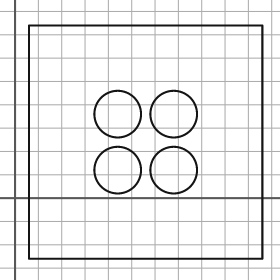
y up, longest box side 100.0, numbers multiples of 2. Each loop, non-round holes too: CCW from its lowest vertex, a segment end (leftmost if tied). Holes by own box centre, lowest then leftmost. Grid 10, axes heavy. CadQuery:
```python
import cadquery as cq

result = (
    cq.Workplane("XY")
    .moveTo(6.0, -26.0)
    .lineTo(106.0, -26.0)
    .lineTo(106.0, 74.0)
    .lineTo(6.0, 74.0)
    .close()
    .moveTo(44.0, 12.0)
    .circle(10.0)
    .moveTo(68.0, 12.0)
    .circle(10.0)
    .moveTo(44.0, 36.0)
    .circle(10.0)
    .moveTo(68.0, 36.0)
    .circle(10.0)
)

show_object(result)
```